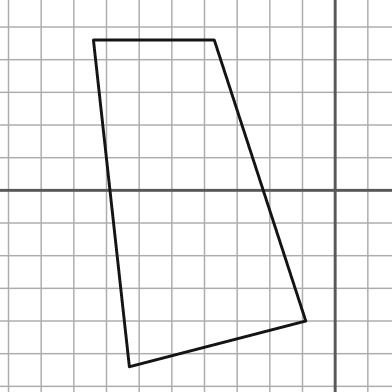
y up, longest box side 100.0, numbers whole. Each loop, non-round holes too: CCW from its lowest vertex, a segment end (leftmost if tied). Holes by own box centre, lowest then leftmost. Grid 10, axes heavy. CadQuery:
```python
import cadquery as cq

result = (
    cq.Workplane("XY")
    .moveTo(-63.0, -54.0)
    .lineTo(-9.0, -40.0)
    .lineTo(-37.0, 46.0)
    .lineTo(-74.0, 46.0)
    .close()
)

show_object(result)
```